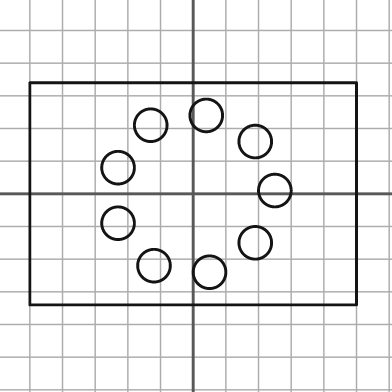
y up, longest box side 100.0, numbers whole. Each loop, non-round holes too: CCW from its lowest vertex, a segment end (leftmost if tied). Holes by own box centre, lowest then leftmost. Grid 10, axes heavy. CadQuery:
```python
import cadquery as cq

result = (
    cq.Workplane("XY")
    .moveTo(-50.0, -34.0)
    .lineTo(50.0, -34.0)
    .lineTo(50.0, 34.0)
    .lineTo(-50.0, 34.0)
    .close()
    .moveTo(5.0, -24.0)
    .circle(5.0)
    .moveTo(-12.0, -22.0)
    .circle(5.0)
    .moveTo(19.0, -15.0)
    .circle(5.0)
    .moveTo(-23.0, -9.0)
    .circle(5.0)
    .moveTo(25.0, 1.0)
    .circle(5.0)
    .moveTo(-23.0, 8.0)
    .circle(5.0)
    .moveTo(19.0, 16.0)
    .circle(5.0)
    .moveTo(-13.0, 21.0)
    .circle(5.0)
    .moveTo(4.0, 24.0)
    .circle(5.0)
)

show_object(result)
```